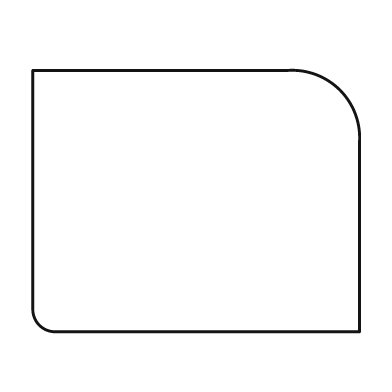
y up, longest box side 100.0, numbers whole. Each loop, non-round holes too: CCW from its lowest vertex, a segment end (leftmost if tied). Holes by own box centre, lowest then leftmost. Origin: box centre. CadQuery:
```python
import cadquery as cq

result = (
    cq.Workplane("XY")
    .moveTo(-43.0, -40.0)
    .lineTo(50.0, -40.0)
    .lineTo(50.0, 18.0)
    .threePointArc((44.0, 34.0), (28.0, 40.0))
    .lineTo(-50.0, 40.0)
    .lineTo(-50.0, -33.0)
    .threePointArc((-48.0, -38.0), (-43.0, -40.0))
    .close()
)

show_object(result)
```